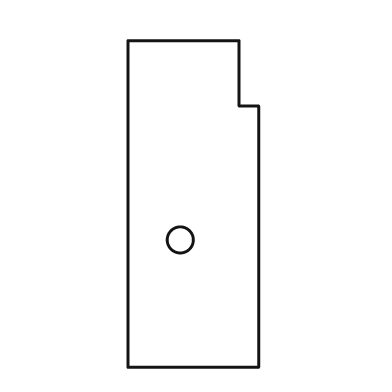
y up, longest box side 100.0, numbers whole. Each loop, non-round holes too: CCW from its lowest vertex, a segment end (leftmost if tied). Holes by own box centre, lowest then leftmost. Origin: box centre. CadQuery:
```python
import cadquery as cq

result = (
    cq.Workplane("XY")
    .moveTo(-20.0, -50.0)
    .lineTo(20.0, -50.0)
    .lineTo(20.0, 30.0)
    .lineTo(14.0, 30.0)
    .lineTo(14.0, 50.0)
    .lineTo(-20.0, 50.0)
    .close()
    .moveTo(-4.0, -11.0)
    .circle(4.0)
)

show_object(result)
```